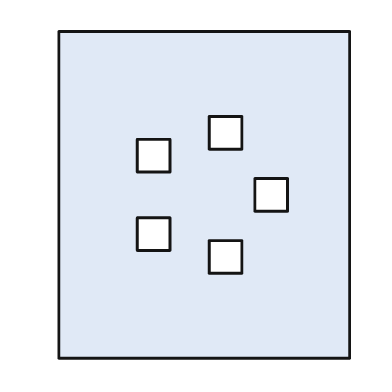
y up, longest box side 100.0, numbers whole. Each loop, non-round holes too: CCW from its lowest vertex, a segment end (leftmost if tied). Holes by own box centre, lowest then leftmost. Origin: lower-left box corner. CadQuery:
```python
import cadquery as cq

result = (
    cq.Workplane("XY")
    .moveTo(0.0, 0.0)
    .lineTo(89.0, 0.0)
    .lineTo(89.0, 100.0)
    .lineTo(0.0, 100.0)
    .close()
    .moveTo(46.0, 26.0)
    .lineTo(56.0, 26.0)
    .lineTo(56.0, 36.0)
    .lineTo(46.0, 36.0)
    .close()
    .moveTo(24.0, 33.0)
    .lineTo(34.0, 33.0)
    .lineTo(34.0, 43.0)
    .lineTo(24.0, 43.0)
    .close()
    .moveTo(60.0, 45.0)
    .lineTo(70.0, 45.0)
    .lineTo(70.0, 55.0)
    .lineTo(60.0, 55.0)
    .close()
    .moveTo(24.0, 57.0)
    .lineTo(34.0, 57.0)
    .lineTo(34.0, 67.0)
    .lineTo(24.0, 67.0)
    .close()
    .moveTo(46.0, 64.0)
    .lineTo(56.0, 64.0)
    .lineTo(56.0, 74.0)
    .lineTo(46.0, 74.0)
    .close()
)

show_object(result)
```